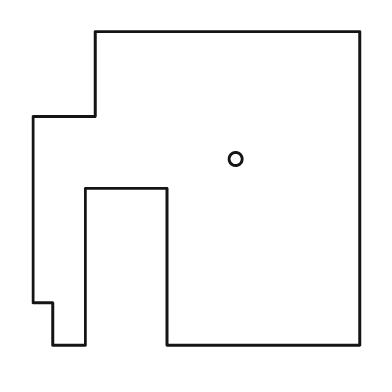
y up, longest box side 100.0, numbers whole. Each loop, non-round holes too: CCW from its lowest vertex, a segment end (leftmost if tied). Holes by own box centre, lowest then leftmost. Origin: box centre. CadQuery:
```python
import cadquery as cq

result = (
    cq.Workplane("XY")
    .moveTo(-44.0, -48.0)
    .lineTo(-34.0, -48.0)
    .lineTo(-34.0, 0.0)
    .lineTo(-9.0, 0.0)
    .lineTo(-9.0, -48.0)
    .lineTo(50.0, -48.0)
    .lineTo(50.0, 48.0)
    .lineTo(-31.0, 48.0)
    .lineTo(-31.0, 22.0)
    .lineTo(-50.0, 22.0)
    .lineTo(-50.0, -35.0)
    .lineTo(-44.0, -35.0)
    .close()
    .moveTo(12.0, 9.0)
    .circle(2.0)
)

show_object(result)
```